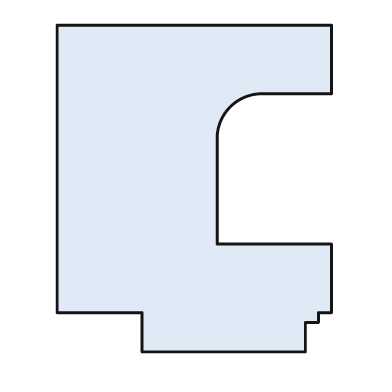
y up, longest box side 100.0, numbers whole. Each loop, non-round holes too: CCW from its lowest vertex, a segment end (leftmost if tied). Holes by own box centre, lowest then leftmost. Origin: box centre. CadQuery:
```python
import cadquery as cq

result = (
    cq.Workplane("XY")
    .moveTo(-16.0, -50.0)
    .lineTo(34.0, -50.0)
    .lineTo(34.0, -41.0)
    .lineTo(38.0, -41.0)
    .lineTo(38.0, -38.0)
    .lineTo(42.0, -38.0)
    .lineTo(42.0, -17.0)
    .lineTo(7.0, -17.0)
    .lineTo(7.0, 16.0)
    .threePointArc((11.0, 25.0), (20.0, 29.0))
    .lineTo(42.0, 29.0)
    .lineTo(42.0, 50.0)
    .lineTo(-42.0, 50.0)
    .lineTo(-42.0, -38.0)
    .lineTo(-16.0, -38.0)
    .close()
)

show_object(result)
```